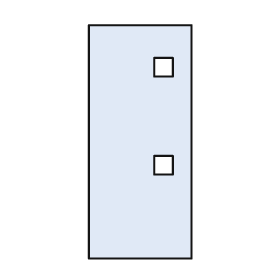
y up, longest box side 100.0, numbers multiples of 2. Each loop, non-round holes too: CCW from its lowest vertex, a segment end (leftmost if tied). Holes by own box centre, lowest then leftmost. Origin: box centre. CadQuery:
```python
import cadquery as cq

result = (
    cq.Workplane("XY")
    .moveTo(-22.0, -50.0)
    .lineTo(22.0, -50.0)
    .lineTo(22.0, 50.0)
    .lineTo(-22.0, 50.0)
    .close()
    .moveTo(6.0, -14.0)
    .lineTo(14.0, -14.0)
    .lineTo(14.0, -6.0)
    .lineTo(6.0, -6.0)
    .close()
    .moveTo(6.0, 28.0)
    .lineTo(14.0, 28.0)
    .lineTo(14.0, 36.0)
    .lineTo(6.0, 36.0)
    .close()
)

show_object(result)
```